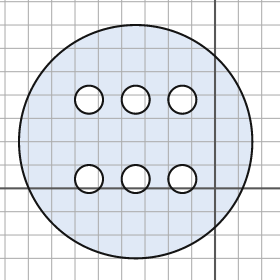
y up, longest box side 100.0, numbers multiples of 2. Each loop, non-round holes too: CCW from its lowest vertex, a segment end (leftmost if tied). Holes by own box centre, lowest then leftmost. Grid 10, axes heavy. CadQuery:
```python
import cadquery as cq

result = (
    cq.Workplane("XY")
    .moveTo(-34.0, 20.0)
    .circle(50.0)
    .moveTo(-54.0, 4.0)
    .circle(6.0)
    .moveTo(-34.0, 4.0)
    .circle(6.0)
    .moveTo(-14.0, 4.0)
    .circle(6.0)
    .moveTo(-54.0, 38.0)
    .circle(6.0)
    .moveTo(-34.0, 38.0)
    .circle(6.0)
    .moveTo(-14.0, 38.0)
    .circle(6.0)
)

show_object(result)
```